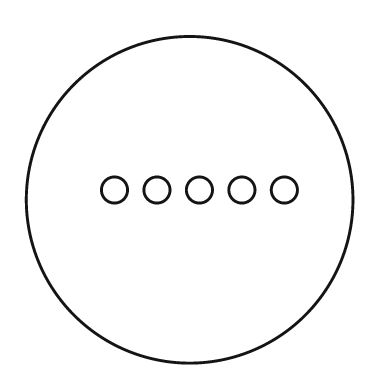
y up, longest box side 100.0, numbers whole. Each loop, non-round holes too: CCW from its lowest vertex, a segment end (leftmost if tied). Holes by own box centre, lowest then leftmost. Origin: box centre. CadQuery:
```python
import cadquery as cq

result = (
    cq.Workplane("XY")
    .moveTo(0.0, 0.0)
    .circle(50.0)
    .moveTo(-23.0, 3.0)
    .circle(4.0)
    .moveTo(-10.0, 3.0)
    .circle(4.0)
    .moveTo(3.0, 3.0)
    .circle(4.0)
    .moveTo(16.0, 3.0)
    .circle(4.0)
    .moveTo(29.0, 3.0)
    .circle(4.0)
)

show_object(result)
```